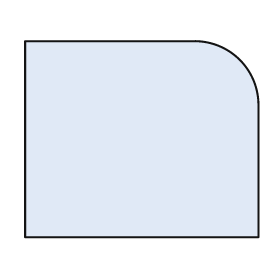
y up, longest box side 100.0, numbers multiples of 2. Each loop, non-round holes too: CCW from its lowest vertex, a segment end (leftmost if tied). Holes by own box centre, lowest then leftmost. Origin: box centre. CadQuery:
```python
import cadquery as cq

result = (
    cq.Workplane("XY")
    .moveTo(-50.0, -42.0)
    .lineTo(50.0, -42.0)
    .lineTo(50.0, 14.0)
    .threePointArc((42.0, 34.0), (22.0, 42.0))
    .lineTo(-50.0, 42.0)
    .close()
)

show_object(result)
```